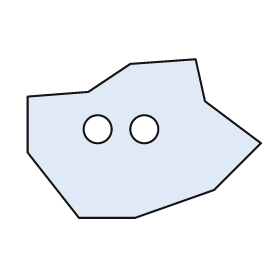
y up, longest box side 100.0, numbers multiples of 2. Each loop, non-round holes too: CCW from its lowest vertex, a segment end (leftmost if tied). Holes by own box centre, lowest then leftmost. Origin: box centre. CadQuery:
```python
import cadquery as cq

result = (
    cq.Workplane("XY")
    .moveTo(-28.0, -34.0)
    .lineTo(-4.0, -34.0)
    .lineTo(30.0, -22.0)
    .lineTo(50.0, -2.0)
    .lineTo(26.0, 16.0)
    .lineTo(22.0, 34.0)
    .lineTo(-6.0, 32.0)
    .lineTo(-24.0, 20.0)
    .lineTo(-50.0, 18.0)
    .lineTo(-50.0, -6.0)
    .close()
    .moveTo(-20.0, 4.0)
    .circle(6.0)
    .moveTo(0.0, 4.0)
    .circle(6.0)
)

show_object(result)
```